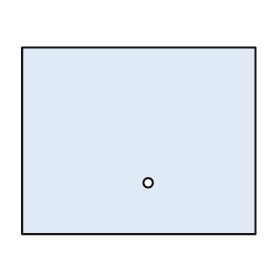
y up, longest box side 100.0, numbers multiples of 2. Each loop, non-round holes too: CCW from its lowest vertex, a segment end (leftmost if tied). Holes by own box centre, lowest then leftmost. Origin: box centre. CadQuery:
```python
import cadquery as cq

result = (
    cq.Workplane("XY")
    .moveTo(-50.0, -40.0)
    .lineTo(50.0, -40.0)
    .lineTo(50.0, 40.0)
    .lineTo(-50.0, 40.0)
    .close()
    .moveTo(4.0, -18.0)
    .circle(2.0)
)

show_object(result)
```